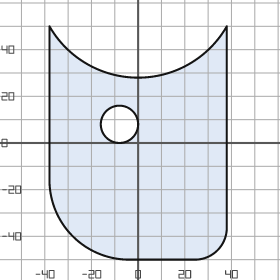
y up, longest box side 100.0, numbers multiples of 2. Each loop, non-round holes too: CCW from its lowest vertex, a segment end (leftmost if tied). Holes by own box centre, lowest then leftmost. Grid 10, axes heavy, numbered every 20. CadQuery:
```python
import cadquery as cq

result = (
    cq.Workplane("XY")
    .moveTo(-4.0, -50.0)
    .lineTo(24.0, -50.0)
    .threePointArc((34.0, -46.0), (38.0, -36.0))
    .lineTo(38.0, 50.0)
    .threePointArc((0.0, 28.0), (-38.0, 50.0))
    .lineTo(-38.0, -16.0)
    .threePointArc((-28.0, -40.0), (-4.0, -50.0))
    .close()
    .moveTo(-8.0, 8.0)
    .circle(8.0)
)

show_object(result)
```